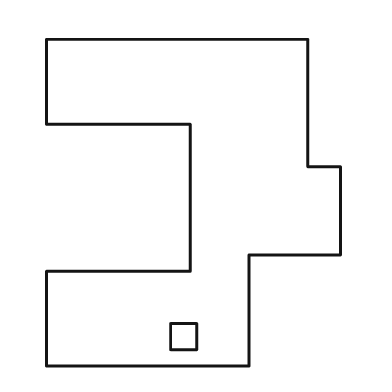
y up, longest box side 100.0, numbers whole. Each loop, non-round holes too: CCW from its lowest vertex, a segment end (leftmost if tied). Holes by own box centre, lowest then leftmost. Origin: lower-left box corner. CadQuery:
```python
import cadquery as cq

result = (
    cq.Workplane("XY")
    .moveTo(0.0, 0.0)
    .lineTo(62.0, 0.0)
    .lineTo(62.0, 34.0)
    .lineTo(90.0, 34.0)
    .lineTo(90.0, 61.0)
    .lineTo(80.0, 61.0)
    .lineTo(80.0, 100.0)
    .lineTo(0.0, 100.0)
    .lineTo(0.0, 74.0)
    .lineTo(44.0, 74.0)
    .lineTo(44.0, 29.0)
    .lineTo(0.0, 29.0)
    .close()
    .moveTo(38.0, 5.0)
    .lineTo(46.0, 5.0)
    .lineTo(46.0, 13.0)
    .lineTo(38.0, 13.0)
    .close()
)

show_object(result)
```